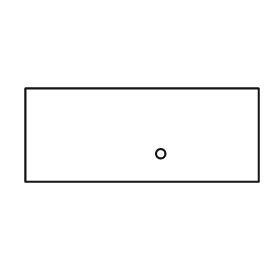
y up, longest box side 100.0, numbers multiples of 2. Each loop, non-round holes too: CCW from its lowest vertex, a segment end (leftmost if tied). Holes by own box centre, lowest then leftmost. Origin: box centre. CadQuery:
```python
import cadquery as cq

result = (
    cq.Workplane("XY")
    .moveTo(-50.0, -20.0)
    .lineTo(50.0, -20.0)
    .lineTo(50.0, 20.0)
    .lineTo(-50.0, 20.0)
    .close()
    .moveTo(8.0, -8.0)
    .circle(2.0)
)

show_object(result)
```